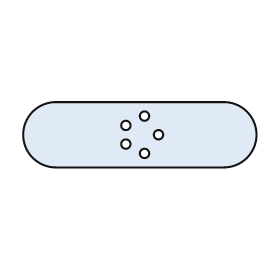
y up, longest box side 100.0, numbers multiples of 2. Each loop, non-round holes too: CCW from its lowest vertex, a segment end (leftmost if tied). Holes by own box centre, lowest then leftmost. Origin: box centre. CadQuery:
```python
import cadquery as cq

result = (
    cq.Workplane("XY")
    .moveTo(-36.0, -14.0)
    .lineTo(36.0, -14.0)
    .threePointArc((50.0, 0.0), (36.0, 14.0))
    .lineTo(-36.0, 14.0)
    .threePointArc((-50.0, 0.0), (-36.0, -14.0))
    .close()
    .moveTo(2.0, -8.0)
    .circle(2.0)
    .moveTo(-6.0, -4.0)
    .circle(2.0)
    .moveTo(8.0, 0.0)
    .circle(2.0)
    .moveTo(-6.0, 4.0)
    .circle(2.0)
    .moveTo(2.0, 8.0)
    .circle(2.0)
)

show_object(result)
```